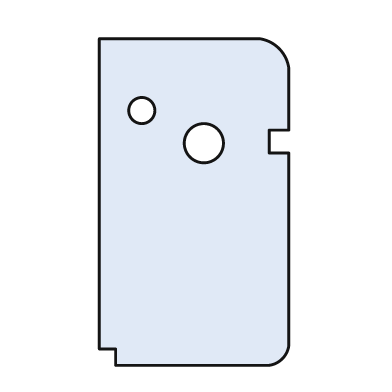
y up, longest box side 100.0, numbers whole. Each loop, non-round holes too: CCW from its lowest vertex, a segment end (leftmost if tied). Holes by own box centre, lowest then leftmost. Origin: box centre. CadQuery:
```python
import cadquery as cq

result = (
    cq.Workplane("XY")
    .moveTo(-24.0, -50.0)
    .lineTo(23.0, -50.0)
    .threePointArc((27.0, -48.0), (29.0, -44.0))
    .lineTo(29.0, 15.0)
    .lineTo(23.0, 15.0)
    .lineTo(23.0, 22.0)
    .lineTo(29.0, 22.0)
    .lineTo(29.0, 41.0)
    .threePointArc((26.0, 47.0), (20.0, 50.0))
    .lineTo(-29.0, 50.0)
    .lineTo(-29.0, -45.0)
    .lineTo(-24.0, -45.0)
    .close()
    .moveTo(3.0, 18.0)
    .circle(6.0)
    .moveTo(-16.0, 28.0)
    .circle(4.0)
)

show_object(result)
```